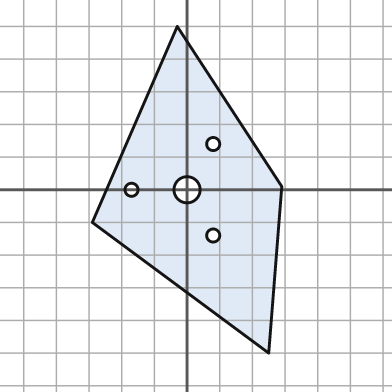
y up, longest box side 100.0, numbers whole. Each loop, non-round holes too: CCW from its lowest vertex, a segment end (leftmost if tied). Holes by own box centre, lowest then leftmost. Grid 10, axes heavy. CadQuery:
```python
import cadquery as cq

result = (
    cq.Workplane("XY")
    .moveTo(25.0, -50.0)
    .lineTo(29.0, 1.0)
    .lineTo(-3.0, 50.0)
    .lineTo(-29.0, -10.0)
    .close()
    .moveTo(8.0, -14.0)
    .circle(2.0)
    .moveTo(-17.0, 0.0)
    .circle(2.0)
    .moveTo(0.0, 0.0)
    .circle(4.0)
    .moveTo(8.0, 14.0)
    .circle(2.0)
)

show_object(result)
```